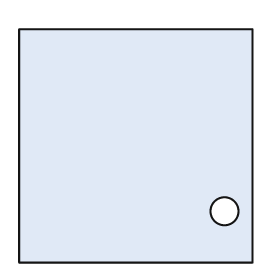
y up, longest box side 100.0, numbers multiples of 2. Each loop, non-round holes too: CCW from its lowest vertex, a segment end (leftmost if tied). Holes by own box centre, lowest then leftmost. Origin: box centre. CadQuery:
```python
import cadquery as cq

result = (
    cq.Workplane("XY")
    .moveTo(-50.0, -50.0)
    .lineTo(50.0, -50.0)
    .lineTo(50.0, 50.0)
    .lineTo(-50.0, 50.0)
    .close()
    .moveTo(38.0, -28.0)
    .circle(6.0)
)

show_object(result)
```